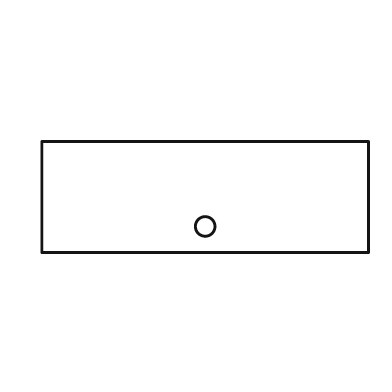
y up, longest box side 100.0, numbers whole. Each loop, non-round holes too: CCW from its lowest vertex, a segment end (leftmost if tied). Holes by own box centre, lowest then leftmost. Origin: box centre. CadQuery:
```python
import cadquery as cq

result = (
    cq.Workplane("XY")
    .moveTo(-50.0, -17.0)
    .lineTo(50.0, -17.0)
    .lineTo(50.0, 17.0)
    .lineTo(-50.0, 17.0)
    .close()
    .moveTo(0.0, -9.0)
    .circle(3.0)
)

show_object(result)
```